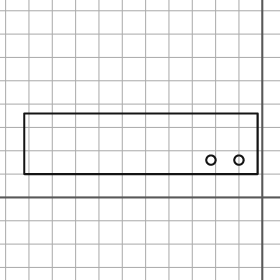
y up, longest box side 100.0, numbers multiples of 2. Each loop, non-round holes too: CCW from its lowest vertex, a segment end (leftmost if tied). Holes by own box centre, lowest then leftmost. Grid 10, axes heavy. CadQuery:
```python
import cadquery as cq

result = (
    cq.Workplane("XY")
    .moveTo(-102.0, 10.0)
    .lineTo(-2.0, 10.0)
    .lineTo(-2.0, 36.0)
    .lineTo(-102.0, 36.0)
    .close()
    .moveTo(-22.0, 16.0)
    .circle(2.0)
    .moveTo(-10.0, 16.0)
    .circle(2.0)
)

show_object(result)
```